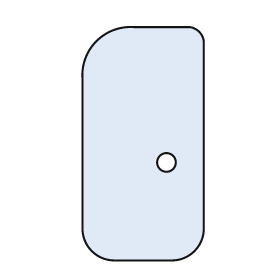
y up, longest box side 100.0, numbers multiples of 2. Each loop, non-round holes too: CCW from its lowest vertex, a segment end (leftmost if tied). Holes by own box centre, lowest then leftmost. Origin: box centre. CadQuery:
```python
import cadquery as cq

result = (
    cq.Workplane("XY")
    .moveTo(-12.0, -50.0)
    .lineTo(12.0, -50.0)
    .threePointArc((22.0, -46.0), (26.0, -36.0))
    .lineTo(26.0, 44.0)
    .threePointArc((24.0, 48.0), (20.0, 50.0))
    .lineTo(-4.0, 50.0)
    .threePointArc((-20.0, 44.0), (-26.0, 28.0))
    .lineTo(-26.0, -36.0)
    .threePointArc((-22.0, -46.0), (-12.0, -50.0))
    .close()
    .moveTo(10.0, -8.0)
    .circle(4.0)
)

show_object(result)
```